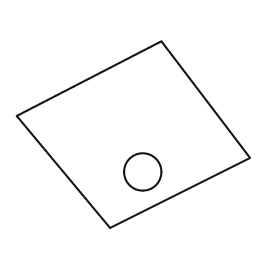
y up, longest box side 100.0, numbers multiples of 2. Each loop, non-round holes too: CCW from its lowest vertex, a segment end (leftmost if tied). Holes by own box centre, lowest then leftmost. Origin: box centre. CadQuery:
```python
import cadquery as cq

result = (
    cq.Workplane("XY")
    .moveTo(-10.0, -40.0)
    .lineTo(50.0, -10.0)
    .lineTo(12.0, 40.0)
    .lineTo(-50.0, 8.0)
    .close()
    .moveTo(4.0, -16.0)
    .circle(8.0)
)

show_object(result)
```